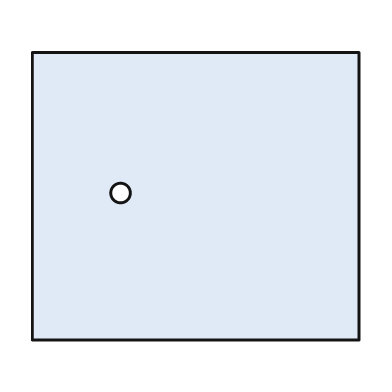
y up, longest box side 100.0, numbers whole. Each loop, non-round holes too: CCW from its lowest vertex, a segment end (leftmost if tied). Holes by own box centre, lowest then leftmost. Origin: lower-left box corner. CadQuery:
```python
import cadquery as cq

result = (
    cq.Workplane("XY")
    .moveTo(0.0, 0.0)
    .lineTo(100.0, 0.0)
    .lineTo(100.0, 88.0)
    .lineTo(0.0, 88.0)
    .close()
    .moveTo(27.0, 45.0)
    .circle(3.0)
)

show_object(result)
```